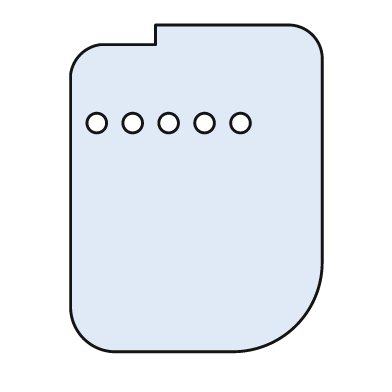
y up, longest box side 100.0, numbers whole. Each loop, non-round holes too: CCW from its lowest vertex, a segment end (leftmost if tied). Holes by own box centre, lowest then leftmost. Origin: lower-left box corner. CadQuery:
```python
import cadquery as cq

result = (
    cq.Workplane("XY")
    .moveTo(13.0, 0.0)
    .lineTo(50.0, 0.0)
    .threePointArc((69.0, 8.0), (77.0, 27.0))
    .lineTo(77.0, 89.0)
    .threePointArc((74.0, 97.0), (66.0, 100.0))
    .lineTo(26.0, 100.0)
    .lineTo(26.0, 94.0)
    .lineTo(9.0, 94.0)
    .threePointArc((3.0, 91.0), (0.0, 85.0))
    .lineTo(0.0, 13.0)
    .threePointArc((4.0, 4.0), (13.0, 0.0))
    .close()
    .moveTo(8.0, 70.0)
    .circle(3.0)
    .moveTo(19.0, 70.0)
    .circle(3.0)
    .moveTo(30.0, 70.0)
    .circle(3.0)
    .moveTo(41.0, 70.0)
    .circle(3.0)
    .moveTo(52.0, 70.0)
    .circle(3.0)
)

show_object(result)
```